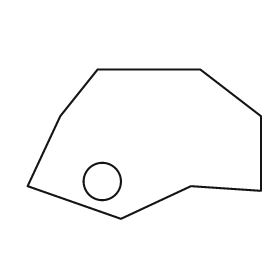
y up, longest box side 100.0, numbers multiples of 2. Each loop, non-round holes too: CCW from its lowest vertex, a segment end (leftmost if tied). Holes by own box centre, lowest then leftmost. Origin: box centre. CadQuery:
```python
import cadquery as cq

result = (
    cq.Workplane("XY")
    .moveTo(-10.0, -32.0)
    .lineTo(20.0, -18.0)
    .lineTo(50.0, -20.0)
    .lineTo(50.0, 12.0)
    .lineTo(24.0, 32.0)
    .lineTo(-20.0, 32.0)
    .lineTo(-36.0, 12.0)
    .lineTo(-50.0, -18.0)
    .close()
    .moveTo(-18.0, -16.0)
    .circle(8.0)
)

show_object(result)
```